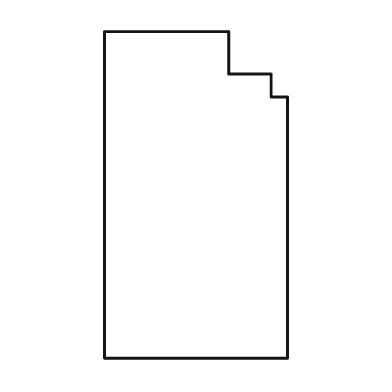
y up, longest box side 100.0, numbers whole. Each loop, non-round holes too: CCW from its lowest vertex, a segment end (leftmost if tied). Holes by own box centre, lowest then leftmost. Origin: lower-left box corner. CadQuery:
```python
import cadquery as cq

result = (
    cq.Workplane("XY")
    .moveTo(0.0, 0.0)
    .lineTo(56.0, 0.0)
    .lineTo(56.0, 80.0)
    .lineTo(51.0, 80.0)
    .lineTo(51.0, 87.0)
    .lineTo(38.0, 87.0)
    .lineTo(38.0, 100.0)
    .lineTo(0.0, 100.0)
    .close()
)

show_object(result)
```